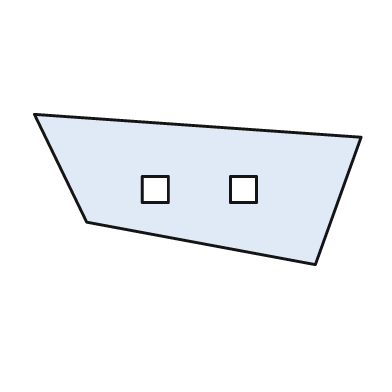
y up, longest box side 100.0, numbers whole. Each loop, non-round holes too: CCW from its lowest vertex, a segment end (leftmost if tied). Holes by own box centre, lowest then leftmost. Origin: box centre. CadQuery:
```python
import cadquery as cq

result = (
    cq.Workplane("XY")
    .moveTo(36.0, -23.0)
    .lineTo(50.0, 16.0)
    .lineTo(-50.0, 23.0)
    .lineTo(-34.0, -10.0)
    .close()
    .moveTo(-17.0, -4.0)
    .lineTo(-9.0, -4.0)
    .lineTo(-9.0, 4.0)
    .lineTo(-17.0, 4.0)
    .close()
    .moveTo(10.0, -4.0)
    .lineTo(18.0, -4.0)
    .lineTo(18.0, 4.0)
    .lineTo(10.0, 4.0)
    .close()
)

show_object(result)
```